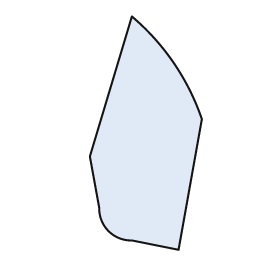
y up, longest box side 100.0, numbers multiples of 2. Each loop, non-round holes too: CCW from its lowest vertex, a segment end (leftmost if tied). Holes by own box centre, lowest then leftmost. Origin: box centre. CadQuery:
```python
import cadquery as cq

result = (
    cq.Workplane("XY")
    .moveTo(14.0, -50.0)
    .lineTo(24.0, 6.0)
    .threePointArc((12.0, 30.0), (-6.0, 50.0))
    .lineTo(-24.0, -10.0)
    .lineTo(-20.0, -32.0)
    .threePointArc((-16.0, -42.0), (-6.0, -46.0))
    .close()
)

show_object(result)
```